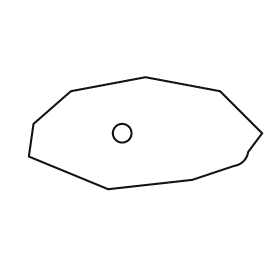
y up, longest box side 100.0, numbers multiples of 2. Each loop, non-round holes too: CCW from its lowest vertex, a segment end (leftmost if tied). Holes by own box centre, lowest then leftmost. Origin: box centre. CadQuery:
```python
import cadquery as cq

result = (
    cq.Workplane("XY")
    .moveTo(-16.0, -24.0)
    .lineTo(20.0, -20.0)
    .lineTo(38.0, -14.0)
    .threePointArc((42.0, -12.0), (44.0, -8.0))
    .lineTo(50.0, 0.0)
    .lineTo(32.0, 18.0)
    .lineTo(0.0, 24.0)
    .lineTo(-32.0, 18.0)
    .lineTo(-48.0, 4.0)
    .lineTo(-50.0, -10.0)
    .close()
    .moveTo(-10.0, 0.0)
    .circle(4.0)
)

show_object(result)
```